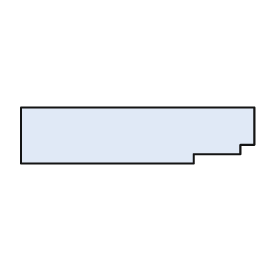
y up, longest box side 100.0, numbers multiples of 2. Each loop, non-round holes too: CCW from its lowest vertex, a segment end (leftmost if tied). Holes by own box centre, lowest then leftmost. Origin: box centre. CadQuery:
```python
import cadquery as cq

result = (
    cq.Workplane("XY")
    .moveTo(-50.0, -12.0)
    .lineTo(24.0, -12.0)
    .lineTo(24.0, -8.0)
    .lineTo(44.0, -8.0)
    .lineTo(44.0, -4.0)
    .lineTo(50.0, -4.0)
    .lineTo(50.0, 12.0)
    .lineTo(-50.0, 12.0)
    .close()
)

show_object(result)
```